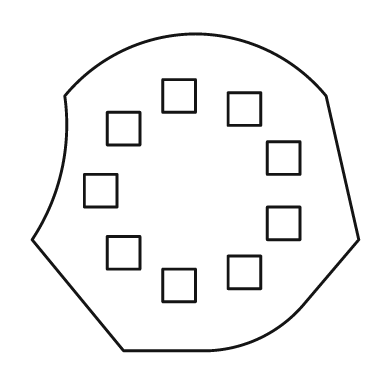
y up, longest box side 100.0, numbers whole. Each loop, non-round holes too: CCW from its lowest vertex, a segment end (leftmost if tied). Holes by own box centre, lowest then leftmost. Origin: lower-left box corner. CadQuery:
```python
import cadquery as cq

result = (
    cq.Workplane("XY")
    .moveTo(28.0, 0.0)
    .lineTo(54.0, 0.0)
    .threePointArc((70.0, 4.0), (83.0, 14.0))
    .lineTo(100.0, 34.0)
    .lineTo(90.0, 78.0)
    .threePointArc((72.0, 92.0), (50.0, 97.0))
    .threePointArc((28.0, 92.0), (10.0, 78.0))
    .threePointArc((9.0, 55.0), (0.0, 34.0))
    .close()
    .moveTo(40.0, 15.0)
    .lineTo(50.0, 15.0)
    .lineTo(50.0, 25.0)
    .lineTo(40.0, 25.0)
    .close()
    .moveTo(60.0, 19.0)
    .lineTo(70.0, 19.0)
    .lineTo(70.0, 29.0)
    .lineTo(60.0, 29.0)
    .close()
    .moveTo(23.0, 25.0)
    .lineTo(33.0, 25.0)
    .lineTo(33.0, 35.0)
    .lineTo(23.0, 35.0)
    .close()
    .moveTo(72.0, 34.0)
    .lineTo(82.0, 34.0)
    .lineTo(82.0, 44.0)
    .lineTo(72.0, 44.0)
    .close()
    .moveTo(16.0, 44.0)
    .lineTo(26.0, 44.0)
    .lineTo(26.0, 54.0)
    .lineTo(16.0, 54.0)
    .close()
    .moveTo(72.0, 54.0)
    .lineTo(82.0, 54.0)
    .lineTo(82.0, 64.0)
    .lineTo(72.0, 64.0)
    .close()
    .moveTo(23.0, 63.0)
    .lineTo(33.0, 63.0)
    .lineTo(33.0, 73.0)
    .lineTo(23.0, 73.0)
    .close()
    .moveTo(60.0, 69.0)
    .lineTo(70.0, 69.0)
    .lineTo(70.0, 79.0)
    .lineTo(60.0, 79.0)
    .close()
    .moveTo(40.0, 73.0)
    .lineTo(50.0, 73.0)
    .lineTo(50.0, 83.0)
    .lineTo(40.0, 83.0)
    .close()
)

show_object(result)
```